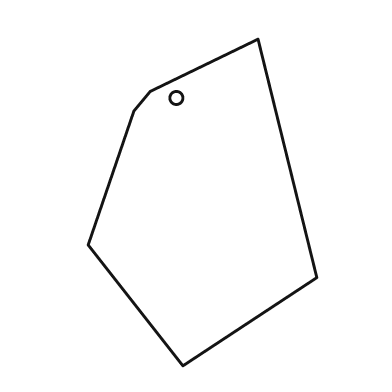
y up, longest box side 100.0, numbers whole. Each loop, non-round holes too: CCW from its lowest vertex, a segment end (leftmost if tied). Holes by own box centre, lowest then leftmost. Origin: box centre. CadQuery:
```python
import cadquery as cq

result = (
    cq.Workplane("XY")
    .moveTo(-6.0, -50.0)
    .lineTo(35.0, -23.0)
    .lineTo(17.0, 50.0)
    .lineTo(-16.0, 34.0)
    .lineTo(-21.0, 28.0)
    .lineTo(-35.0, -13.0)
    .close()
    .moveTo(-8.0, 32.0)
    .circle(2.0)
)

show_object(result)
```